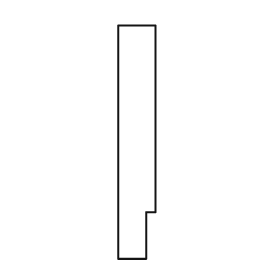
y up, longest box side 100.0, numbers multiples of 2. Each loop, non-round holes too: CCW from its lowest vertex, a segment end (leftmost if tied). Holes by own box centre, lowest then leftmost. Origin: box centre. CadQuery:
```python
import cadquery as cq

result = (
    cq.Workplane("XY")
    .moveTo(-8.0, -50.0)
    .lineTo(4.0, -50.0)
    .lineTo(4.0, -30.0)
    .lineTo(8.0, -30.0)
    .lineTo(8.0, 50.0)
    .lineTo(-8.0, 50.0)
    .close()
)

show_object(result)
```